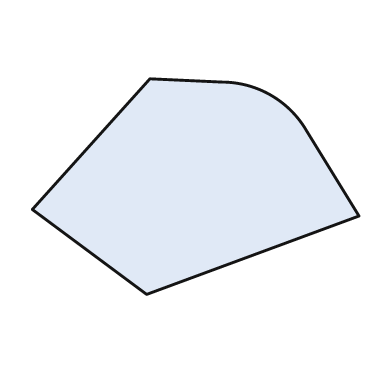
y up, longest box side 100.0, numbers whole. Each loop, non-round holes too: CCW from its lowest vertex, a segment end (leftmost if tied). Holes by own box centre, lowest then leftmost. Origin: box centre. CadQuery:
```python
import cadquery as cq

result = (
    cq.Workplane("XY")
    .moveTo(-15.0, -33.0)
    .lineTo(50.0, -9.0)
    .lineTo(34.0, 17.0)
    .threePointArc((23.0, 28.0), (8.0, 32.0))
    .lineTo(-14.0, 33.0)
    .lineTo(-50.0, -7.0)
    .close()
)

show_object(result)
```